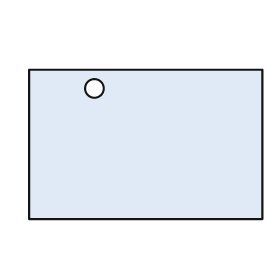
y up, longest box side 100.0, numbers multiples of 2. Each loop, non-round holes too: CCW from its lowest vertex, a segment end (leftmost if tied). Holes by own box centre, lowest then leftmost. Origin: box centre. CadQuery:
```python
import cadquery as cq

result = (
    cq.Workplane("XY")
    .moveTo(-50.0, -32.0)
    .lineTo(50.0, -32.0)
    .lineTo(50.0, 32.0)
    .lineTo(-50.0, 32.0)
    .close()
    .moveTo(-22.0, 24.0)
    .circle(4.0)
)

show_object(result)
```